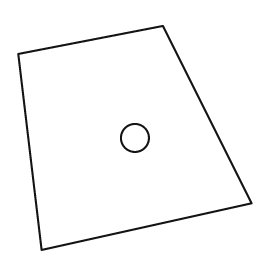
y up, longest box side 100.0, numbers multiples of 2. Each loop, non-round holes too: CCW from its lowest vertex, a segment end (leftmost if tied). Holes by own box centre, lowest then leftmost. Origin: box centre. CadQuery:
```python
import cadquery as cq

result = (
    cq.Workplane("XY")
    .moveTo(-40.0, -48.0)
    .lineTo(50.0, -28.0)
    .lineTo(12.0, 48.0)
    .lineTo(-50.0, 36.0)
    .close()
    .moveTo(0.0, 0.0)
    .circle(6.0)
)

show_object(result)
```